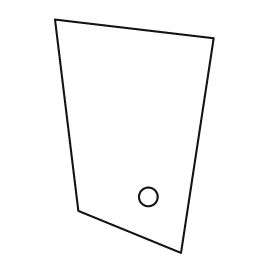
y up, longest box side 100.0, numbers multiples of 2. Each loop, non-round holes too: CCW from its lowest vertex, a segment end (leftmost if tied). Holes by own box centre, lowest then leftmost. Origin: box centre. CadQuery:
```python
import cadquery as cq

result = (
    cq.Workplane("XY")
    .moveTo(20.0, -50.0)
    .lineTo(34.0, 42.0)
    .lineTo(-34.0, 50.0)
    .lineTo(-24.0, -32.0)
    .close()
    .moveTo(6.0, -26.0)
    .circle(4.0)
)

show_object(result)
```